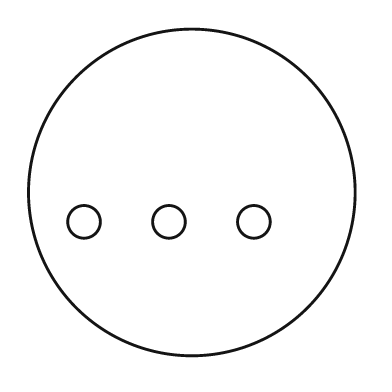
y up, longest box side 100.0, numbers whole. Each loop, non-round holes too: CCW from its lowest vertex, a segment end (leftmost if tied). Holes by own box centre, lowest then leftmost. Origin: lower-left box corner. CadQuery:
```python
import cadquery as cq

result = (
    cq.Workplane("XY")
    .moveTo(50.0, 50.0)
    .circle(50.0)
    .moveTo(17.0, 41.0)
    .circle(5.0)
    .moveTo(43.0, 41.0)
    .circle(5.0)
    .moveTo(69.0, 41.0)
    .circle(5.0)
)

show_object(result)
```